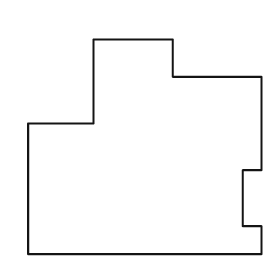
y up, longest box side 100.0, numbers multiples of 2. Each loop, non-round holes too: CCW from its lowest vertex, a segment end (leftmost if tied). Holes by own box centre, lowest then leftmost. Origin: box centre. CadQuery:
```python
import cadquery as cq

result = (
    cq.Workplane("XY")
    .moveTo(-50.0, -46.0)
    .lineTo(50.0, -46.0)
    .lineTo(50.0, -34.0)
    .lineTo(42.0, -34.0)
    .lineTo(42.0, -10.0)
    .lineTo(50.0, -10.0)
    .lineTo(50.0, 30.0)
    .lineTo(12.0, 30.0)
    .lineTo(12.0, 46.0)
    .lineTo(-22.0, 46.0)
    .lineTo(-22.0, 10.0)
    .lineTo(-50.0, 10.0)
    .close()
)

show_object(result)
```